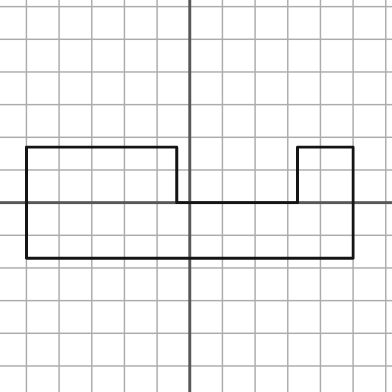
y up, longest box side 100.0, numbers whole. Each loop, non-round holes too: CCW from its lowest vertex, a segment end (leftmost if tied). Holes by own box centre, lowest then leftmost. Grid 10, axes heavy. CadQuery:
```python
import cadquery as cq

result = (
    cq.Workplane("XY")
    .moveTo(-50.0, -17.0)
    .lineTo(50.0, -17.0)
    .lineTo(50.0, 17.0)
    .lineTo(33.0, 17.0)
    .lineTo(33.0, 0.0)
    .lineTo(-4.0, 0.0)
    .lineTo(-4.0, 17.0)
    .lineTo(-50.0, 17.0)
    .close()
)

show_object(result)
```